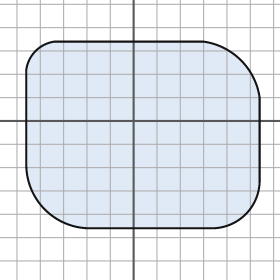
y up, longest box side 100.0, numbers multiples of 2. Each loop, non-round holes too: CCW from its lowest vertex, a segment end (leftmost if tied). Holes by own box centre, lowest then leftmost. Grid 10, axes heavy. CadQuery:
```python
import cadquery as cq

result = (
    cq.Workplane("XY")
    .moveTo(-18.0, -46.0)
    .lineTo(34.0, -46.0)
    .threePointArc((48.0, -40.0), (54.0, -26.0))
    .lineTo(54.0, 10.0)
    .threePointArc((46.0, 26.0), (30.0, 34.0))
    .lineTo(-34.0, 34.0)
    .threePointArc((-42.0, 30.0), (-46.0, 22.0))
    .lineTo(-46.0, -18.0)
    .threePointArc((-38.0, -38.0), (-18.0, -46.0))
    .close()
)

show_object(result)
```